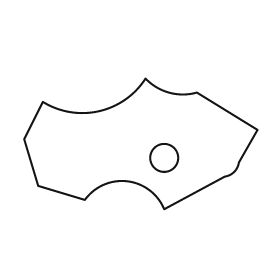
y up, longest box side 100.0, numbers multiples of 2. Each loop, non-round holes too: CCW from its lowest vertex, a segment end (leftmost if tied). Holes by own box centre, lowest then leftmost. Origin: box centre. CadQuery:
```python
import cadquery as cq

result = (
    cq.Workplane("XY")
    .moveTo(10.0, -28.0)
    .lineTo(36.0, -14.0)
    .threePointArc((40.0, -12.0), (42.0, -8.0))
    .lineTo(50.0, 6.0)
    .lineTo(24.0, 22.0)
    .threePointArc((12.0, 22.0), (2.0, 28.0))
    .threePointArc((-18.0, 14.0), (-42.0, 18.0))
    .lineTo(-50.0, 2.0)
    .lineTo(-44.0, -18.0)
    .lineTo(-24.0, -24.0)
    .threePointArc((-6.0, -16.0), (10.0, -28.0))
    .close()
    .moveTo(10.0, -6.0)
    .circle(6.0)
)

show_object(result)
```